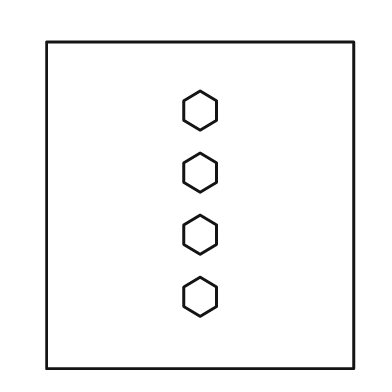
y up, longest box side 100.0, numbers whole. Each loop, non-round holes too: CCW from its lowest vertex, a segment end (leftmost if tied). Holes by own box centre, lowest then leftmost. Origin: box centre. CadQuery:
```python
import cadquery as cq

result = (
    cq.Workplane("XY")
    .moveTo(-47.0, -50.0)
    .lineTo(47.0, -50.0)
    .lineTo(47.0, 50.0)
    .lineTo(-47.0, 50.0)
    .close()
    .moveTo(0.0, -34.0)
    .lineTo(5.0, -31.0)
    .lineTo(5.0, -25.0)
    .lineTo(0.0, -22.0)
    .lineTo(-5.0, -25.0)
    .lineTo(-5.0, -31.0)
    .close()
    .moveTo(0.0, -15.0)
    .lineTo(5.0, -12.0)
    .lineTo(5.0, -6.0)
    .lineTo(0.0, -3.0)
    .lineTo(-5.0, -6.0)
    .lineTo(-5.0, -12.0)
    .close()
    .moveTo(0.0, 4.0)
    .lineTo(5.0, 7.0)
    .lineTo(5.0, 13.0)
    .lineTo(0.0, 16.0)
    .lineTo(-5.0, 13.0)
    .lineTo(-5.0, 7.0)
    .close()
    .moveTo(0.0, 23.0)
    .lineTo(5.0, 26.0)
    .lineTo(5.0, 32.0)
    .lineTo(0.0, 35.0)
    .lineTo(-5.0, 32.0)
    .lineTo(-5.0, 26.0)
    .close()
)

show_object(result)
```